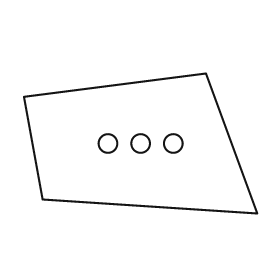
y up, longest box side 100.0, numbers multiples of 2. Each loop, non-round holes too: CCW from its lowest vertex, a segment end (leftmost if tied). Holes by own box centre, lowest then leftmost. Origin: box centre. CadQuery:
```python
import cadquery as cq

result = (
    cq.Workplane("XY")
    .moveTo(50.0, -30.0)
    .lineTo(28.0, 30.0)
    .lineTo(-50.0, 20.0)
    .lineTo(-42.0, -24.0)
    .close()
    .moveTo(-14.0, 0.0)
    .circle(4.0)
    .moveTo(0.0, 0.0)
    .circle(4.0)
    .moveTo(14.0, 0.0)
    .circle(4.0)
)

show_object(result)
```